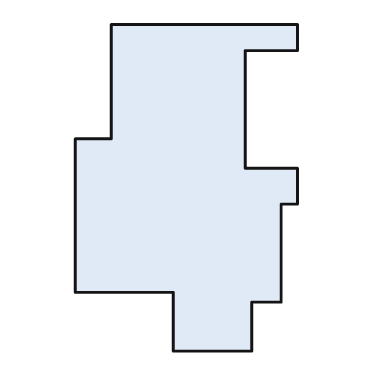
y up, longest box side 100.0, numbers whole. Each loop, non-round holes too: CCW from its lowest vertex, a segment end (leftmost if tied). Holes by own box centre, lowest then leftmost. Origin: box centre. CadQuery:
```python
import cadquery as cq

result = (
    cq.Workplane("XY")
    .moveTo(-4.0, -50.0)
    .lineTo(20.0, -50.0)
    .lineTo(20.0, -35.0)
    .lineTo(29.0, -35.0)
    .lineTo(29.0, -5.0)
    .lineTo(34.0, -5.0)
    .lineTo(34.0, 6.0)
    .lineTo(18.0, 6.0)
    .lineTo(18.0, 42.0)
    .lineTo(34.0, 42.0)
    .lineTo(34.0, 50.0)
    .lineTo(-23.0, 50.0)
    .lineTo(-23.0, 15.0)
    .lineTo(-34.0, 15.0)
    .lineTo(-34.0, -32.0)
    .lineTo(-4.0, -32.0)
    .close()
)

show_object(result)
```